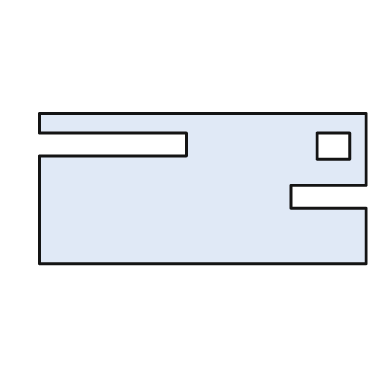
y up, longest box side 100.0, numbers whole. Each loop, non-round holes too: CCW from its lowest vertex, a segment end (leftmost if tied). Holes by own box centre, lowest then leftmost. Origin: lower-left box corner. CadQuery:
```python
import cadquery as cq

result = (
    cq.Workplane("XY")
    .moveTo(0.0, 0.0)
    .lineTo(100.0, 0.0)
    .lineTo(100.0, 17.0)
    .lineTo(77.0, 17.0)
    .lineTo(77.0, 24.0)
    .lineTo(100.0, 24.0)
    .lineTo(100.0, 46.0)
    .lineTo(0.0, 46.0)
    .lineTo(0.0, 40.0)
    .lineTo(45.0, 40.0)
    .lineTo(45.0, 33.0)
    .lineTo(0.0, 33.0)
    .close()
    .moveTo(85.0, 32.0)
    .lineTo(95.0, 32.0)
    .lineTo(95.0, 40.0)
    .lineTo(85.0, 40.0)
    .close()
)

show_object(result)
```